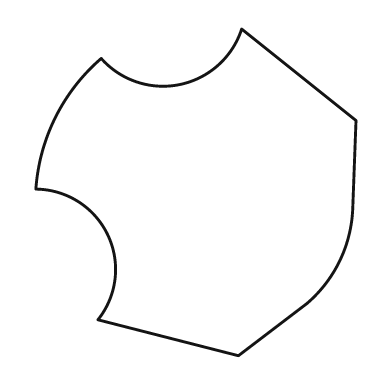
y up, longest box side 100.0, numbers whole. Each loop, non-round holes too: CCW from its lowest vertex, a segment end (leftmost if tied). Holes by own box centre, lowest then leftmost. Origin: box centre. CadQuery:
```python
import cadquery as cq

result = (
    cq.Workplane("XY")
    .moveTo(13.0, -50.0)
    .lineTo(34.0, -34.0)
    .threePointArc((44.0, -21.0), (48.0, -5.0))
    .lineTo(49.0, 22.0)
    .lineTo(14.0, 50.0)
    .threePointArc((-5.0, 33.0), (-29.0, 41.0))
    .threePointArc((-43.0, 23.0), (-49.0, 1.0))
    .threePointArc((-27.0, -13.0), (-30.0, -39.0))
    .close()
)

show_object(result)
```